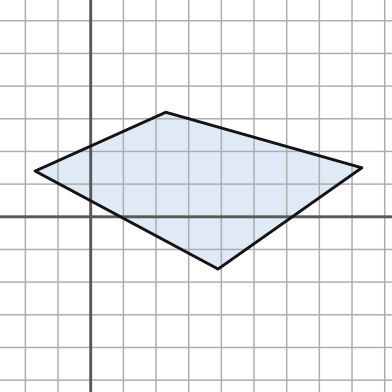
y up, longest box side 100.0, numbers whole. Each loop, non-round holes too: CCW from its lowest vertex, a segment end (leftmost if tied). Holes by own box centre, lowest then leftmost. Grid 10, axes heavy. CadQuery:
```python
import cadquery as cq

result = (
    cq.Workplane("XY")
    .moveTo(39.0, -16.0)
    .lineTo(83.0, 15.0)
    .lineTo(23.0, 32.0)
    .lineTo(-17.0, 14.0)
    .close()
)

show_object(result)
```